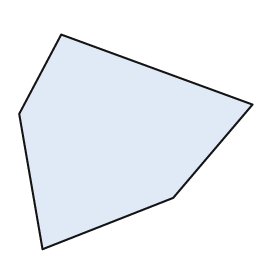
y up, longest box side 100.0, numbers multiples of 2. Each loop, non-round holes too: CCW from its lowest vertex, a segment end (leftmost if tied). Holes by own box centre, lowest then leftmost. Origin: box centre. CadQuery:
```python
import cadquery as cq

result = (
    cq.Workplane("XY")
    .moveTo(-40.0, -46.0)
    .lineTo(16.0, -24.0)
    .lineTo(50.0, 16.0)
    .lineTo(-32.0, 46.0)
    .lineTo(-50.0, 12.0)
    .close()
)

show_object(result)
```